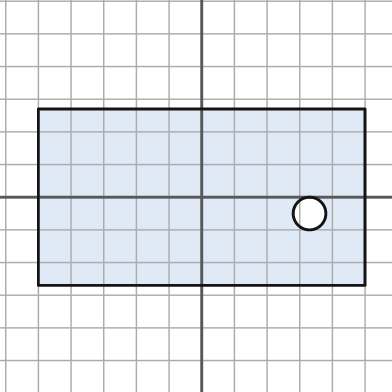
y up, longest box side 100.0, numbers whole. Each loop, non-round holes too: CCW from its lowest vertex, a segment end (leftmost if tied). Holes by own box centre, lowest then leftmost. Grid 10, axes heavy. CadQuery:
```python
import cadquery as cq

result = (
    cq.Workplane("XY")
    .moveTo(-50.0, -27.0)
    .lineTo(50.0, -27.0)
    .lineTo(50.0, 27.0)
    .lineTo(-50.0, 27.0)
    .close()
    .moveTo(33.0, -5.0)
    .circle(5.0)
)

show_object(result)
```